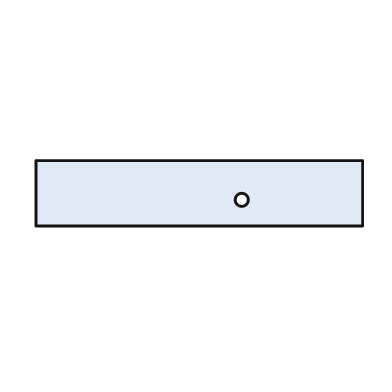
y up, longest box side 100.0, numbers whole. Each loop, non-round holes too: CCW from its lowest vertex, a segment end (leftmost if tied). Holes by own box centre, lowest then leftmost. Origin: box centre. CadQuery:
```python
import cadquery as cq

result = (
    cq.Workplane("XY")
    .moveTo(-50.0, -10.0)
    .lineTo(50.0, -10.0)
    .lineTo(50.0, 10.0)
    .lineTo(-50.0, 10.0)
    .close()
    .moveTo(13.0, -2.0)
    .circle(2.0)
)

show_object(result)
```